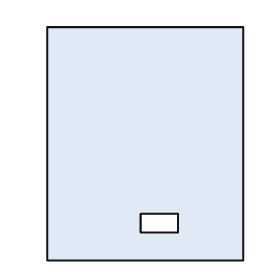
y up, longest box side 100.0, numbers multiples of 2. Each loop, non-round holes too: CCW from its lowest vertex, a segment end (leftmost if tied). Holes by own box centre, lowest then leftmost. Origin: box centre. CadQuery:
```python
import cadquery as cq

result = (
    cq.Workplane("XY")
    .moveTo(-42.0, -50.0)
    .lineTo(42.0, -50.0)
    .lineTo(42.0, 50.0)
    .lineTo(-42.0, 50.0)
    .close()
    .moveTo(-2.0, -38.0)
    .lineTo(14.0, -38.0)
    .lineTo(14.0, -30.0)
    .lineTo(-2.0, -30.0)
    .close()
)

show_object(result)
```